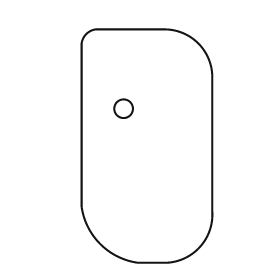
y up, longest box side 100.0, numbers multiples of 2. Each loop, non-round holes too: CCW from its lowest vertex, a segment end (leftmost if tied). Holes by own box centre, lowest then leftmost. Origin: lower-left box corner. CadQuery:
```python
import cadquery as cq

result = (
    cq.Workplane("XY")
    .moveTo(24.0, 0.0)
    .lineTo(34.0, 0.0)
    .threePointArc((50.0, 6.0), (56.0, 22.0))
    .lineTo(56.0, 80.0)
    .threePointArc((50.0, 94.0), (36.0, 100.0))
    .lineTo(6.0, 100.0)
    .threePointArc((2.0, 98.0), (0.0, 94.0))
    .lineTo(0.0, 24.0)
    .threePointArc((8.0, 8.0), (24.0, 0.0))
    .close()
    .moveTo(18.0, 66.0)
    .circle(4.0)
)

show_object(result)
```